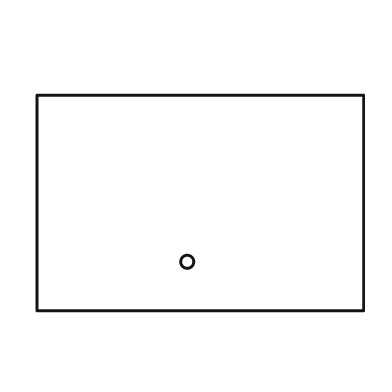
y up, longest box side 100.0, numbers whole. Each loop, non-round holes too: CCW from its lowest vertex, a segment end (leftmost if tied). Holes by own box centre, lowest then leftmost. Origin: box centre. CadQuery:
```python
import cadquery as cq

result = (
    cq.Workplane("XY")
    .moveTo(-50.0, -33.0)
    .lineTo(50.0, -33.0)
    .lineTo(50.0, 33.0)
    .lineTo(-50.0, 33.0)
    .close()
    .moveTo(-4.0, -18.0)
    .circle(2.0)
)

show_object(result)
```